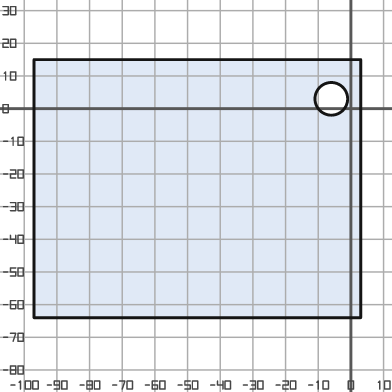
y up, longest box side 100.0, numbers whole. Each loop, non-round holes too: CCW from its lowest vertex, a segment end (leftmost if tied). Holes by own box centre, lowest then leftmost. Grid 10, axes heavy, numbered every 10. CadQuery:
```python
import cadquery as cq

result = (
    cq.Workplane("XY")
    .moveTo(-97.0, -64.0)
    .lineTo(3.0, -64.0)
    .lineTo(3.0, 15.0)
    .lineTo(-97.0, 15.0)
    .close()
    .moveTo(-6.0, 3.0)
    .circle(5.0)
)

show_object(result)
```